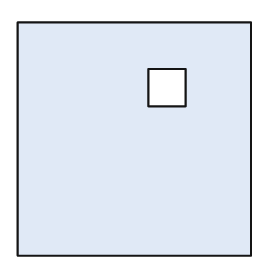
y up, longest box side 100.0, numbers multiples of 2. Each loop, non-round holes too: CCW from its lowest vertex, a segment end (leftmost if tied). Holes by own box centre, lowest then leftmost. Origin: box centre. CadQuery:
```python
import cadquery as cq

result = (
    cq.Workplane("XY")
    .moveTo(-50.0, -50.0)
    .lineTo(50.0, -50.0)
    .lineTo(50.0, 50.0)
    .lineTo(-50.0, 50.0)
    .close()
    .moveTo(6.0, 14.0)
    .lineTo(22.0, 14.0)
    .lineTo(22.0, 30.0)
    .lineTo(6.0, 30.0)
    .close()
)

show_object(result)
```